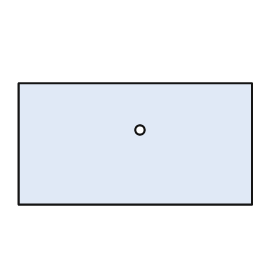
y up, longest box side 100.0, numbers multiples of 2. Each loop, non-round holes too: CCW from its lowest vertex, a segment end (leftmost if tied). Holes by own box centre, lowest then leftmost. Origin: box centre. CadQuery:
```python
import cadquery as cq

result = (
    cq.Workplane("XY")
    .moveTo(-50.0, -26.0)
    .lineTo(50.0, -26.0)
    .lineTo(50.0, 26.0)
    .lineTo(-50.0, 26.0)
    .close()
    .moveTo(2.0, 6.0)
    .circle(2.0)
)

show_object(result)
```